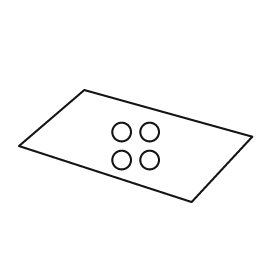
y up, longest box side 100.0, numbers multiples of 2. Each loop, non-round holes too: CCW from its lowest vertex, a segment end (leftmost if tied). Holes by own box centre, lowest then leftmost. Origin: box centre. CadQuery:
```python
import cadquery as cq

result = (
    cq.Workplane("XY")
    .moveTo(24.0, -24.0)
    .lineTo(50.0, 4.0)
    .lineTo(-22.0, 24.0)
    .lineTo(-50.0, 0.0)
    .close()
    .moveTo(-6.0, -6.0)
    .circle(4.0)
    .moveTo(6.0, -6.0)
    .circle(4.0)
    .moveTo(-6.0, 6.0)
    .circle(4.0)
    .moveTo(6.0, 6.0)
    .circle(4.0)
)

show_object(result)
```